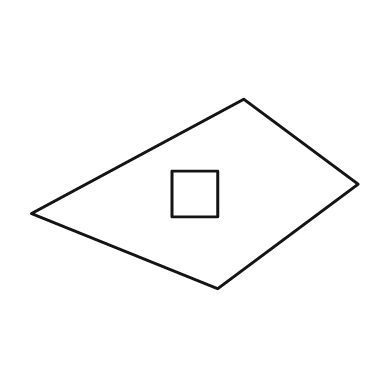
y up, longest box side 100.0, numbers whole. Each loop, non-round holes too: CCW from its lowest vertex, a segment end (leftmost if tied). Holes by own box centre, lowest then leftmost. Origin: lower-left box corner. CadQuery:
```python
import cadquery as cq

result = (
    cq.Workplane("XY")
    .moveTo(57.0, 0.0)
    .lineTo(100.0, 32.0)
    .lineTo(65.0, 58.0)
    .lineTo(0.0, 23.0)
    .close()
    .moveTo(43.0, 22.0)
    .lineTo(57.0, 22.0)
    .lineTo(57.0, 36.0)
    .lineTo(43.0, 36.0)
    .close()
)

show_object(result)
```